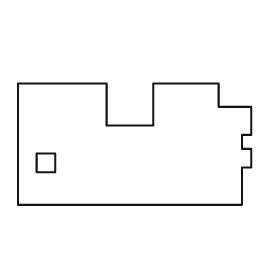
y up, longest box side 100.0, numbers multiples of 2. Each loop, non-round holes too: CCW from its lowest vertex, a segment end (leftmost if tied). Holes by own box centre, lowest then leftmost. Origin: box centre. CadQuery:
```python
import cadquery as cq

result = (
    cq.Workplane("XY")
    .moveTo(-50.0, -26.0)
    .lineTo(46.0, -26.0)
    .lineTo(46.0, -10.0)
    .lineTo(50.0, -10.0)
    .lineTo(50.0, -2.0)
    .lineTo(46.0, -2.0)
    .lineTo(46.0, 4.0)
    .lineTo(50.0, 4.0)
    .lineTo(50.0, 16.0)
    .lineTo(36.0, 16.0)
    .lineTo(36.0, 26.0)
    .lineTo(8.0, 26.0)
    .lineTo(8.0, 8.0)
    .lineTo(-12.0, 8.0)
    .lineTo(-12.0, 26.0)
    .lineTo(-50.0, 26.0)
    .close()
    .moveTo(-42.0, -12.0)
    .lineTo(-34.0, -12.0)
    .lineTo(-34.0, -4.0)
    .lineTo(-42.0, -4.0)
    .close()
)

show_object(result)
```